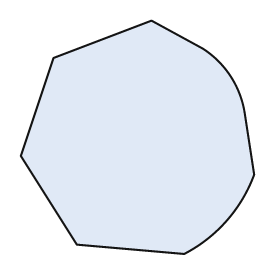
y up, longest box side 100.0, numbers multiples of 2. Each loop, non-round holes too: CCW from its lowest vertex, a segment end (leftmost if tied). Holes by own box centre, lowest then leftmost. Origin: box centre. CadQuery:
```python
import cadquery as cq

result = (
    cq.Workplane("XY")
    .moveTo(20.0, -50.0)
    .threePointArc((38.0, -36.0), (50.0, -16.0))
    .lineTo(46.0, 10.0)
    .threePointArc((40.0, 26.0), (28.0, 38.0))
    .lineTo(6.0, 50.0)
    .lineTo(-36.0, 34.0)
    .lineTo(-50.0, -8.0)
    .lineTo(-26.0, -46.0)
    .close()
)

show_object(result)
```